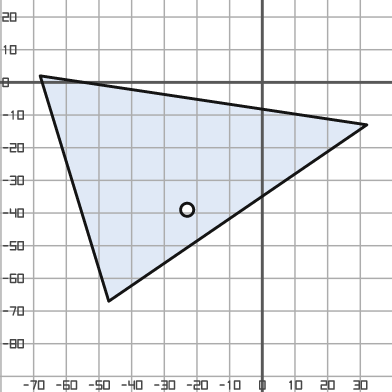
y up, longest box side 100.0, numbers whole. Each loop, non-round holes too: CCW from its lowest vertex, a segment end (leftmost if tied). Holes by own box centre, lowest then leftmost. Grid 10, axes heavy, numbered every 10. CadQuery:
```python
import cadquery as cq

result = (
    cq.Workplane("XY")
    .moveTo(-47.0, -67.0)
    .lineTo(32.0, -13.0)
    .lineTo(-68.0, 2.0)
    .close()
    .moveTo(-23.0, -39.0)
    .circle(2.0)
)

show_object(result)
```